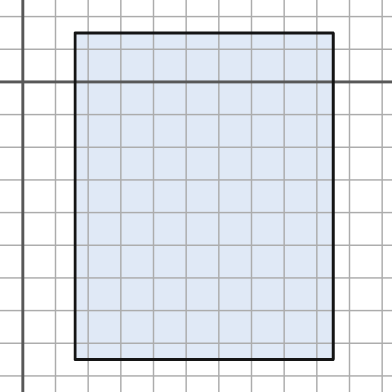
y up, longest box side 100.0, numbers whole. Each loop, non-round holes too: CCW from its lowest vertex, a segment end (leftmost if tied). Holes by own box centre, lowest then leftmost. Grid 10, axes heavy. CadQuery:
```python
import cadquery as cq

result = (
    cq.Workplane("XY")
    .moveTo(16.0, -85.0)
    .lineTo(95.0, -85.0)
    .lineTo(95.0, 15.0)
    .lineTo(16.0, 15.0)
    .close()
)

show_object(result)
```